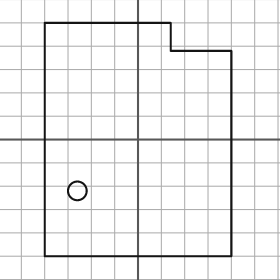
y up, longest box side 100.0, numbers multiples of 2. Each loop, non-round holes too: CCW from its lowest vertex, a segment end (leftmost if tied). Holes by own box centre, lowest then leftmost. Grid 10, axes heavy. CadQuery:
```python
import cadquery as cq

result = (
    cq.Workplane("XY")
    .moveTo(-40.0, -50.0)
    .lineTo(40.0, -50.0)
    .lineTo(40.0, 38.0)
    .lineTo(14.0, 38.0)
    .lineTo(14.0, 50.0)
    .lineTo(-40.0, 50.0)
    .close()
    .moveTo(-26.0, -22.0)
    .circle(4.0)
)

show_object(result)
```